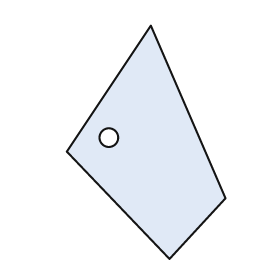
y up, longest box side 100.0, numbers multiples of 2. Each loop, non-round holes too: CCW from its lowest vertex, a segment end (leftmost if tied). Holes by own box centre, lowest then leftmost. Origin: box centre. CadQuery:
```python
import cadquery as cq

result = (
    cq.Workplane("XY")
    .moveTo(10.0, -50.0)
    .lineTo(34.0, -24.0)
    .lineTo(2.0, 50.0)
    .lineTo(-34.0, -4.0)
    .close()
    .moveTo(-16.0, 2.0)
    .circle(4.0)
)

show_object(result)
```